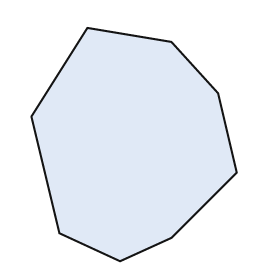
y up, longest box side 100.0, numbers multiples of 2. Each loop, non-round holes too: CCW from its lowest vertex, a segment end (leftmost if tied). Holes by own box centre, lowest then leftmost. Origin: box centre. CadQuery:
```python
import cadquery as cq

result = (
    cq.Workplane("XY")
    .moveTo(-6.0, -50.0)
    .lineTo(16.0, -40.0)
    .lineTo(44.0, -12.0)
    .lineTo(36.0, 22.0)
    .lineTo(16.0, 44.0)
    .lineTo(-20.0, 50.0)
    .lineTo(-44.0, 12.0)
    .lineTo(-32.0, -38.0)
    .close()
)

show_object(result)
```